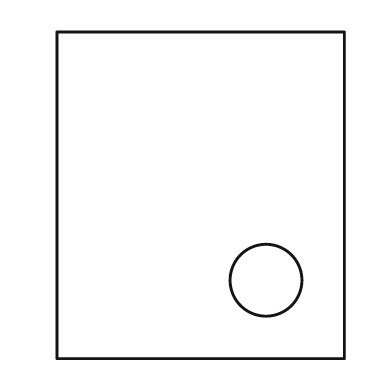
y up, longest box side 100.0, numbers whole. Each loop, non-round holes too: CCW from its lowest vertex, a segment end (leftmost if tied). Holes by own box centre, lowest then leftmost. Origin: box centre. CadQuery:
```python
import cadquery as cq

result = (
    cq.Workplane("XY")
    .moveTo(-44.0, -50.0)
    .lineTo(44.0, -50.0)
    .lineTo(44.0, 50.0)
    .lineTo(-44.0, 50.0)
    .close()
    .moveTo(20.0, -26.0)
    .circle(11.0)
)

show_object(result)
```